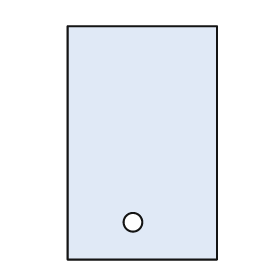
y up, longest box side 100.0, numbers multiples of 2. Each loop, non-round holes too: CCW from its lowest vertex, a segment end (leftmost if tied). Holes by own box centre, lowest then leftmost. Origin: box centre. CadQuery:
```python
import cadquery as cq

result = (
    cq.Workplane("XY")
    .moveTo(-32.0, -50.0)
    .lineTo(32.0, -50.0)
    .lineTo(32.0, 50.0)
    .lineTo(-32.0, 50.0)
    .close()
    .moveTo(-4.0, -34.0)
    .circle(4.0)
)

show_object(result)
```